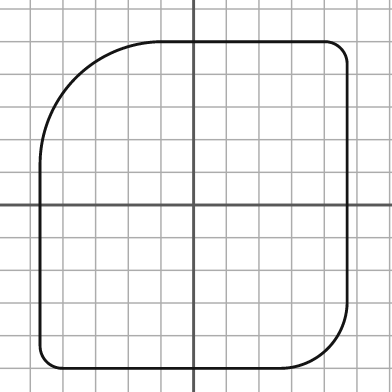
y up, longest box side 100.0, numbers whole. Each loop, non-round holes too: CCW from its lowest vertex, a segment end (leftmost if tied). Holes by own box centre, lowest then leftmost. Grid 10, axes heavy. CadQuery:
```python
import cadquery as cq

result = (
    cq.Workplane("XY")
    .moveTo(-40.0, -50.0)
    .lineTo(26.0, -50.0)
    .threePointArc((41.0, -44.0), (47.0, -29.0))
    .lineTo(47.0, 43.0)
    .threePointArc((45.0, 48.0), (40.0, 50.0))
    .lineTo(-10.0, 50.0)
    .threePointArc((-36.0, 39.0), (-47.0, 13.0))
    .lineTo(-47.0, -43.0)
    .threePointArc((-45.0, -48.0), (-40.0, -50.0))
    .close()
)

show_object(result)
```